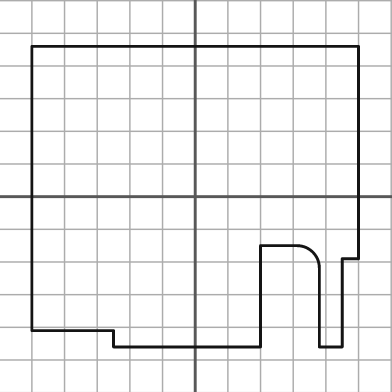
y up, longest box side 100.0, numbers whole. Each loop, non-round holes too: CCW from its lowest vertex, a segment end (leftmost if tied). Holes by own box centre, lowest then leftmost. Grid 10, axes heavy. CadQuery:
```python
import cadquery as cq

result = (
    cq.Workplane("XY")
    .moveTo(-25.0, -46.0)
    .lineTo(20.0, -46.0)
    .lineTo(20.0, -15.0)
    .lineTo(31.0, -15.0)
    .threePointArc((36.0, -17.0), (38.0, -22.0))
    .lineTo(38.0, -46.0)
    .lineTo(45.0, -46.0)
    .lineTo(45.0, -19.0)
    .lineTo(50.0, -19.0)
    .lineTo(50.0, 46.0)
    .lineTo(-50.0, 46.0)
    .lineTo(-50.0, -41.0)
    .lineTo(-25.0, -41.0)
    .close()
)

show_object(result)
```